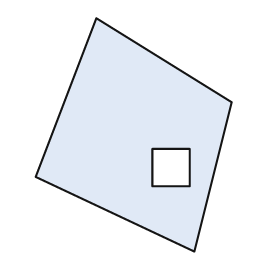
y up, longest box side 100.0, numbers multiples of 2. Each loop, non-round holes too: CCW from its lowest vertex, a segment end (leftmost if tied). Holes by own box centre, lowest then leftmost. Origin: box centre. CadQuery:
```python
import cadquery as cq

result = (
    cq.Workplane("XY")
    .moveTo(26.0, -50.0)
    .lineTo(42.0, 14.0)
    .lineTo(-16.0, 50.0)
    .lineTo(-42.0, -18.0)
    .close()
    .moveTo(8.0, -22.0)
    .lineTo(24.0, -22.0)
    .lineTo(24.0, -6.0)
    .lineTo(8.0, -6.0)
    .close()
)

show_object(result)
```